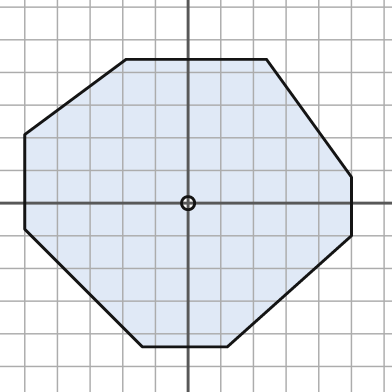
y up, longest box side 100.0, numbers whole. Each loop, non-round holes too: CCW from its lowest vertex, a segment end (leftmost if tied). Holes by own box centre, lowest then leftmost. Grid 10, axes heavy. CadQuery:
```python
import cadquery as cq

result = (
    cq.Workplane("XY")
    .moveTo(-14.0, -44.0)
    .lineTo(12.0, -44.0)
    .lineTo(50.0, -10.0)
    .lineTo(50.0, 8.0)
    .lineTo(24.0, 44.0)
    .lineTo(-19.0, 44.0)
    .lineTo(-50.0, 21.0)
    .lineTo(-50.0, -8.0)
    .close()
    .moveTo(0.0, 0.0)
    .circle(2.0)
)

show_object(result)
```